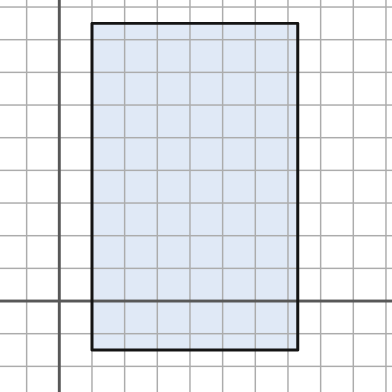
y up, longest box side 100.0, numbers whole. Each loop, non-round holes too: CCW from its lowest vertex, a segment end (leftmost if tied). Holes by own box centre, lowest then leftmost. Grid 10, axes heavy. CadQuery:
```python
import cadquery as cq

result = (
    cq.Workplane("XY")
    .moveTo(10.0, -15.0)
    .lineTo(73.0, -15.0)
    .lineTo(73.0, 85.0)
    .lineTo(10.0, 85.0)
    .close()
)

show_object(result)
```